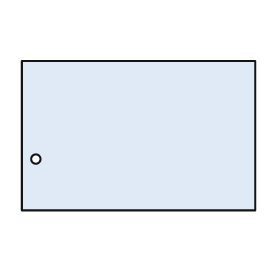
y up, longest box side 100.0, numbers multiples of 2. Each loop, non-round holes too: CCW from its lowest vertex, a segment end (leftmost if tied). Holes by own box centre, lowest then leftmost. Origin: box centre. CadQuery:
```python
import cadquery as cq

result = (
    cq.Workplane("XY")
    .moveTo(-50.0, -32.0)
    .lineTo(50.0, -32.0)
    .lineTo(50.0, 32.0)
    .lineTo(-50.0, 32.0)
    .close()
    .moveTo(-44.0, -10.0)
    .circle(2.0)
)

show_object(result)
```